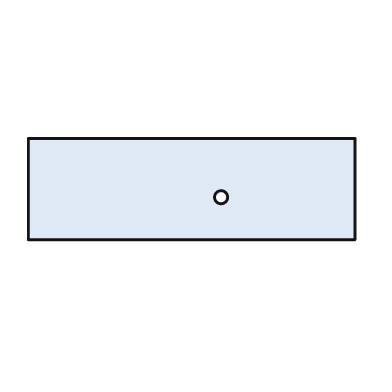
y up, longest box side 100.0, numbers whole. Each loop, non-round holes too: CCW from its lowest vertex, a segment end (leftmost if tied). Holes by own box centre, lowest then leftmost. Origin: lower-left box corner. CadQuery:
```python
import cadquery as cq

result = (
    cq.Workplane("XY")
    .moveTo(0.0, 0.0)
    .lineTo(100.0, 0.0)
    .lineTo(100.0, 31.0)
    .lineTo(0.0, 31.0)
    .close()
    .moveTo(59.0, 13.0)
    .circle(2.0)
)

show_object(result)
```